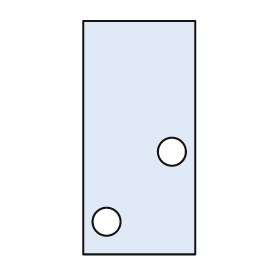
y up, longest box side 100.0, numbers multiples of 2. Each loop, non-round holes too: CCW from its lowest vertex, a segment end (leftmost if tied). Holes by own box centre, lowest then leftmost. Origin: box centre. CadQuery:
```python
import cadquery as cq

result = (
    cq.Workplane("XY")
    .moveTo(-24.0, -50.0)
    .lineTo(24.0, -50.0)
    .lineTo(24.0, 50.0)
    .lineTo(-24.0, 50.0)
    .close()
    .moveTo(-14.0, -36.0)
    .circle(6.0)
    .moveTo(14.0, -6.0)
    .circle(6.0)
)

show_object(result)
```